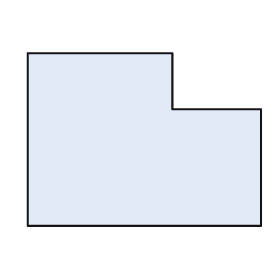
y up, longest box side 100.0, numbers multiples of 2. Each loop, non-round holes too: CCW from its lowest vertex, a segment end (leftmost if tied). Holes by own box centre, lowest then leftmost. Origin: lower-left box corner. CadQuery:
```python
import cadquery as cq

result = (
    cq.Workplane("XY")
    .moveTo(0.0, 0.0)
    .lineTo(100.0, 0.0)
    .lineTo(100.0, 50.0)
    .lineTo(62.0, 50.0)
    .lineTo(62.0, 74.0)
    .lineTo(0.0, 74.0)
    .close()
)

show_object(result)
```